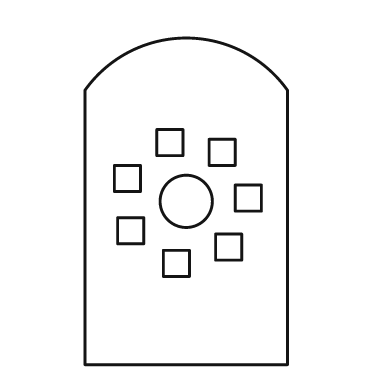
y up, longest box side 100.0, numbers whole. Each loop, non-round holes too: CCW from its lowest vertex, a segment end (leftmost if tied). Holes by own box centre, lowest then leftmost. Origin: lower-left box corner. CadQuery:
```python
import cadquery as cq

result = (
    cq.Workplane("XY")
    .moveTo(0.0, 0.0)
    .lineTo(62.0, 0.0)
    .lineTo(62.0, 84.0)
    .threePointArc((31.0, 100.0), (0.0, 84.0))
    .close()
    .moveTo(24.0, 27.0)
    .lineTo(32.0, 27.0)
    .lineTo(32.0, 35.0)
    .lineTo(24.0, 35.0)
    .close()
    .moveTo(40.0, 32.0)
    .lineTo(48.0, 32.0)
    .lineTo(48.0, 40.0)
    .lineTo(40.0, 40.0)
    .close()
    .moveTo(10.0, 37.0)
    .lineTo(18.0, 37.0)
    .lineTo(18.0, 45.0)
    .lineTo(10.0, 45.0)
    .close()
    .moveTo(31.0, 50.0)
    .circle(8.0)
    .moveTo(46.0, 47.0)
    .lineTo(54.0, 47.0)
    .lineTo(54.0, 55.0)
    .lineTo(46.0, 55.0)
    .close()
    .moveTo(9.0, 53.0)
    .lineTo(17.0, 53.0)
    .lineTo(17.0, 61.0)
    .lineTo(9.0, 61.0)
    .close()
    .moveTo(38.0, 61.0)
    .lineTo(46.0, 61.0)
    .lineTo(46.0, 69.0)
    .lineTo(38.0, 69.0)
    .close()
    .moveTo(22.0, 64.0)
    .lineTo(30.0, 64.0)
    .lineTo(30.0, 72.0)
    .lineTo(22.0, 72.0)
    .close()
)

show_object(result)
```